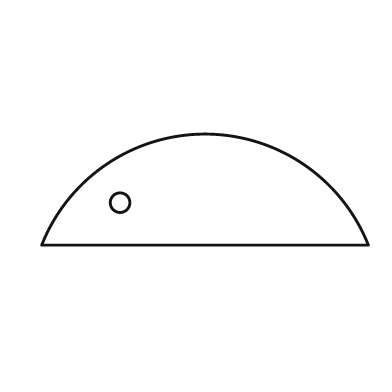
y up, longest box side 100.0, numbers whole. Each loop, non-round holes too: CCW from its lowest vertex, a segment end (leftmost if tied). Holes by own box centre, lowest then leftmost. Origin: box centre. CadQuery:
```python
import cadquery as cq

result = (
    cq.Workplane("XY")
    .moveTo(-50.0, -17.0)
    .lineTo(50.0, -17.0)
    .threePointArc((0.0, 17.0), (-50.0, -17.0))
    .close()
    .moveTo(-26.0, -4.0)
    .circle(3.0)
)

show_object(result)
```